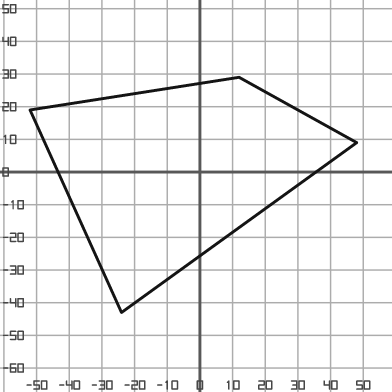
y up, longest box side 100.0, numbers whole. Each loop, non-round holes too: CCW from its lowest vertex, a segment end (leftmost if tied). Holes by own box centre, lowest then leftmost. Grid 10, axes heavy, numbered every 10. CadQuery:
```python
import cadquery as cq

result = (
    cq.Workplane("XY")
    .moveTo(-24.0, -43.0)
    .lineTo(48.0, 9.0)
    .lineTo(12.0, 29.0)
    .lineTo(-52.0, 19.0)
    .close()
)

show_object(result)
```